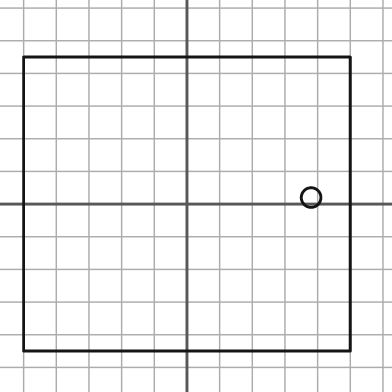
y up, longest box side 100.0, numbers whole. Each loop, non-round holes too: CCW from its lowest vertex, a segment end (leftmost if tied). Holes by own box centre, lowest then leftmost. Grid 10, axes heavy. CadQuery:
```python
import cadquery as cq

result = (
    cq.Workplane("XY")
    .moveTo(-50.0, -45.0)
    .lineTo(50.0, -45.0)
    .lineTo(50.0, 45.0)
    .lineTo(-50.0, 45.0)
    .close()
    .moveTo(38.0, 2.0)
    .circle(3.0)
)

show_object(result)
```